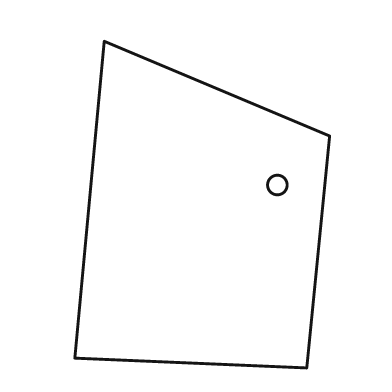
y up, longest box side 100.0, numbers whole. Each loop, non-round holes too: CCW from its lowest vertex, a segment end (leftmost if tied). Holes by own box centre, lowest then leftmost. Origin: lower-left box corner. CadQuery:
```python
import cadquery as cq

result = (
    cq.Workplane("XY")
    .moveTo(71.0, 0.0)
    .lineTo(78.0, 71.0)
    .lineTo(9.0, 100.0)
    .lineTo(0.0, 3.0)
    .close()
    .moveTo(62.0, 56.0)
    .circle(3.0)
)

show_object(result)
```